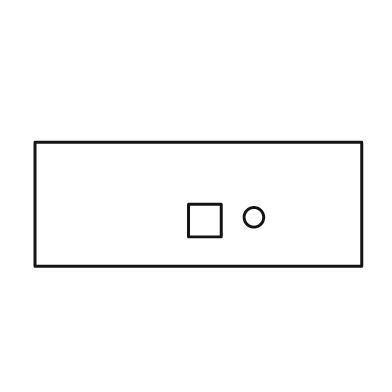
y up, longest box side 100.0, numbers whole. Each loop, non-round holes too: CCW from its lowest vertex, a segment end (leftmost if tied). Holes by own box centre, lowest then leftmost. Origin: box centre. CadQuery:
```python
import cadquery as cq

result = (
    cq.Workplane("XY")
    .moveTo(-50.0, -19.0)
    .lineTo(50.0, -19.0)
    .lineTo(50.0, 19.0)
    .lineTo(-50.0, 19.0)
    .close()
    .moveTo(-3.0, -10.0)
    .lineTo(7.0, -10.0)
    .lineTo(7.0, 0.0)
    .lineTo(-3.0, 0.0)
    .close()
    .moveTo(17.0, -4.0)
    .circle(3.0)
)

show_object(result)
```